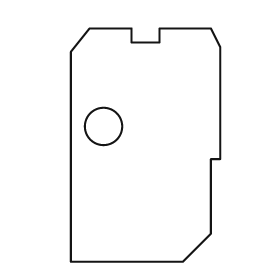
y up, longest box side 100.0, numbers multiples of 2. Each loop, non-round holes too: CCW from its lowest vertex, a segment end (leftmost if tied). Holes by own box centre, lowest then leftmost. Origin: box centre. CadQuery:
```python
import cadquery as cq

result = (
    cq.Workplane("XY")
    .moveTo(-32.0, -50.0)
    .lineTo(16.0, -50.0)
    .lineTo(28.0, -38.0)
    .lineTo(28.0, -6.0)
    .lineTo(32.0, -6.0)
    .lineTo(32.0, 42.0)
    .lineTo(28.0, 50.0)
    .lineTo(6.0, 50.0)
    .lineTo(6.0, 44.0)
    .lineTo(-6.0, 44.0)
    .lineTo(-6.0, 50.0)
    .lineTo(-24.0, 50.0)
    .lineTo(-32.0, 40.0)
    .close()
    .moveTo(-18.0, 8.0)
    .circle(8.0)
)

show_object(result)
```